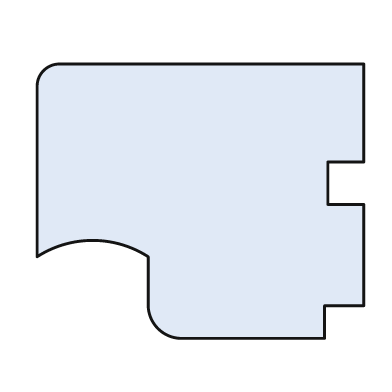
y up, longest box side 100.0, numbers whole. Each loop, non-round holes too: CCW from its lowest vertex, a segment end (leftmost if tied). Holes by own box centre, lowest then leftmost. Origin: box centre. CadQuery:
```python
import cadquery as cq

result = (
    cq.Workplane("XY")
    .moveTo(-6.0, -42.0)
    .lineTo(38.0, -42.0)
    .lineTo(38.0, -32.0)
    .lineTo(50.0, -32.0)
    .lineTo(50.0, -1.0)
    .lineTo(39.0, -1.0)
    .lineTo(39.0, 12.0)
    .lineTo(50.0, 12.0)
    .lineTo(50.0, 42.0)
    .lineTo(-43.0, 42.0)
    .threePointArc((-48.0, 40.0), (-50.0, 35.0))
    .lineTo(-50.0, -17.0)
    .threePointArc((-33.0, -12.0), (-16.0, -17.0))
    .lineTo(-16.0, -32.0)
    .threePointArc((-13.0, -39.0), (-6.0, -42.0))
    .close()
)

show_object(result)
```